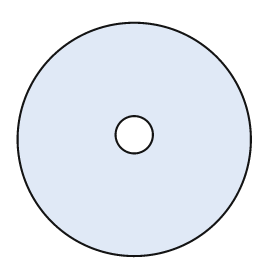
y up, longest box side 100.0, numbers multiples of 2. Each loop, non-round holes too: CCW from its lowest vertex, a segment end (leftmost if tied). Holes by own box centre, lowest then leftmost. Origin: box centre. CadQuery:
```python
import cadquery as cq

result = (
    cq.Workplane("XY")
    .moveTo(0.0, 0.0)
    .circle(50.0)
    .moveTo(0.0, 2.0)
    .circle(8.0)
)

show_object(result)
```